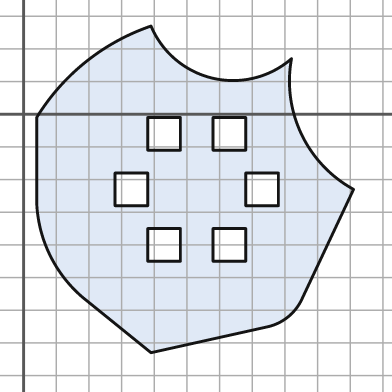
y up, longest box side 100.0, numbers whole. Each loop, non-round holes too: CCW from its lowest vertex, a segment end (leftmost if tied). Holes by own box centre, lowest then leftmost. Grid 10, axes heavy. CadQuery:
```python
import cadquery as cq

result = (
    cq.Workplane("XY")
    .moveTo(39.0, -73.0)
    .lineTo(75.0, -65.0)
    .threePointArc((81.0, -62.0), (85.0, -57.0))
    .lineTo(101.0, -23.0)
    .threePointArc((85.0, -6.0), (82.0, 17.0))
    .threePointArc((58.0, 11.0), (39.0, 27.0))
    .threePointArc((19.0, 16.0), (4.0, -1.0))
    .lineTo(4.0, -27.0)
    .threePointArc((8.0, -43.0), (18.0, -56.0))
    .close()
    .moveTo(38.0, -45.0)
    .lineTo(48.0, -45.0)
    .lineTo(48.0, -35.0)
    .lineTo(38.0, -35.0)
    .close()
    .moveTo(58.0, -45.0)
    .lineTo(68.0, -45.0)
    .lineTo(68.0, -35.0)
    .lineTo(58.0, -35.0)
    .close()
    .moveTo(28.0, -28.0)
    .lineTo(38.0, -28.0)
    .lineTo(38.0, -18.0)
    .lineTo(28.0, -18.0)
    .close()
    .moveTo(68.0, -28.0)
    .lineTo(78.0, -28.0)
    .lineTo(78.0, -18.0)
    .lineTo(68.0, -18.0)
    .close()
    .moveTo(38.0, -11.0)
    .lineTo(48.0, -11.0)
    .lineTo(48.0, -1.0)
    .lineTo(38.0, -1.0)
    .close()
    .moveTo(58.0, -11.0)
    .lineTo(68.0, -11.0)
    .lineTo(68.0, -1.0)
    .lineTo(58.0, -1.0)
    .close()
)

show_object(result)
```